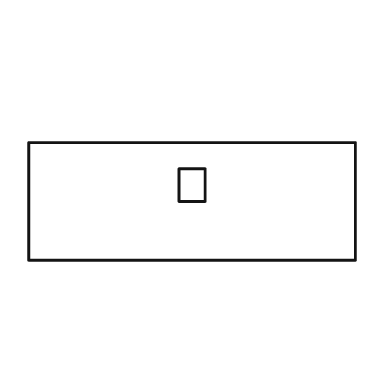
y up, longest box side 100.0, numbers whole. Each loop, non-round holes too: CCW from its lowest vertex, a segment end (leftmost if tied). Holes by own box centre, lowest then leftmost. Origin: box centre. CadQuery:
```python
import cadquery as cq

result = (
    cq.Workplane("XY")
    .moveTo(-50.0, -18.0)
    .lineTo(50.0, -18.0)
    .lineTo(50.0, 18.0)
    .lineTo(-50.0, 18.0)
    .close()
    .moveTo(-4.0, 0.0)
    .lineTo(4.0, 0.0)
    .lineTo(4.0, 10.0)
    .lineTo(-4.0, 10.0)
    .close()
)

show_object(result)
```